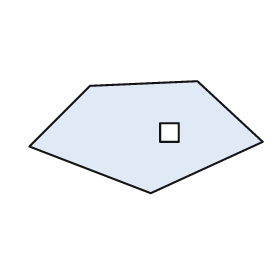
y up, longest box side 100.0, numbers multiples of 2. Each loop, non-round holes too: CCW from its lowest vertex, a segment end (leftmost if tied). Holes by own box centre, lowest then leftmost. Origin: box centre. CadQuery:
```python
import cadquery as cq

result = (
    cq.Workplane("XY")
    .moveTo(2.0, -24.0)
    .lineTo(50.0, -2.0)
    .lineTo(22.0, 24.0)
    .lineTo(-24.0, 22.0)
    .lineTo(-50.0, -4.0)
    .close()
    .moveTo(6.0, -2.0)
    .lineTo(14.0, -2.0)
    .lineTo(14.0, 6.0)
    .lineTo(6.0, 6.0)
    .close()
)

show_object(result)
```